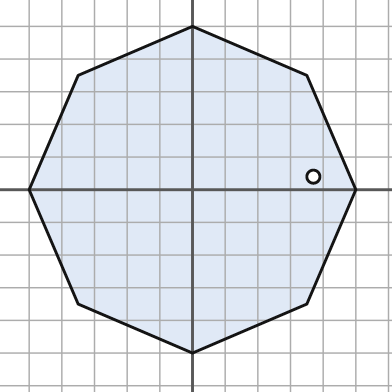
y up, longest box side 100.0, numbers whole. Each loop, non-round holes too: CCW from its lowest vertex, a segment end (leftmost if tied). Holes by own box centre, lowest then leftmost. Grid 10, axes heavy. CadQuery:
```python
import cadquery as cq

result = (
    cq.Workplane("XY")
    .moveTo(0.0, -50.0)
    .lineTo(35.0, -35.0)
    .lineTo(50.0, 0.0)
    .lineTo(35.0, 35.0)
    .lineTo(0.0, 50.0)
    .lineTo(-35.0, 35.0)
    .lineTo(-50.0, 0.0)
    .lineTo(-35.0, -35.0)
    .close()
    .moveTo(37.0, 4.0)
    .circle(2.0)
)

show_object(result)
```